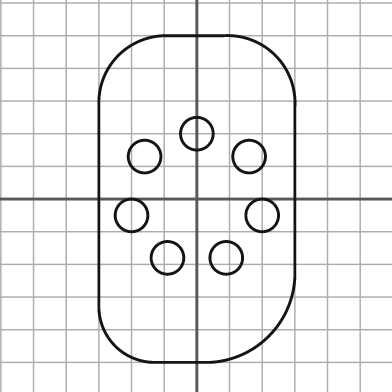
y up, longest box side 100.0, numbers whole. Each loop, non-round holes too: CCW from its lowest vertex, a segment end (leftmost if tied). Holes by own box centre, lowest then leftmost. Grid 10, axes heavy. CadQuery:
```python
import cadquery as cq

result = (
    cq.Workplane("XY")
    .moveTo(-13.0, -50.0)
    .lineTo(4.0, -50.0)
    .threePointArc((22.0, -42.0), (30.0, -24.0))
    .lineTo(30.0, 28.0)
    .threePointArc((24.0, 44.0), (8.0, 50.0))
    .lineTo(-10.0, 50.0)
    .threePointArc((-24.0, 44.0), (-30.0, 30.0))
    .lineTo(-30.0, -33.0)
    .threePointArc((-25.0, -45.0), (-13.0, -50.0))
    .close()
    .moveTo(-9.0, -18.0)
    .circle(5.0)
    .moveTo(9.0, -18.0)
    .circle(5.0)
    .moveTo(-20.0, -5.0)
    .circle(5.0)
    .moveTo(20.0, -5.0)
    .circle(5.0)
    .moveTo(-16.0, 13.0)
    .circle(5.0)
    .moveTo(16.0, 13.0)
    .circle(5.0)
    .moveTo(0.0, 20.0)
    .circle(5.0)
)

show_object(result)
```